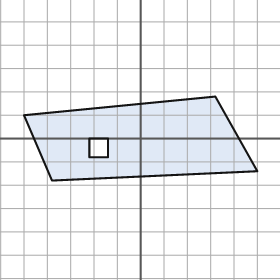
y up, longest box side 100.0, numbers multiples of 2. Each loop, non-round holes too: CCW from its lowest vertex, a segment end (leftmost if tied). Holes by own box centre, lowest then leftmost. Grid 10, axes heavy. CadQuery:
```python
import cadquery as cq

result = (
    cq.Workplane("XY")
    .moveTo(-38.0, -18.0)
    .lineTo(50.0, -14.0)
    .lineTo(32.0, 18.0)
    .lineTo(-50.0, 10.0)
    .close()
    .moveTo(-22.0, -8.0)
    .lineTo(-14.0, -8.0)
    .lineTo(-14.0, 0.0)
    .lineTo(-22.0, 0.0)
    .close()
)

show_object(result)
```